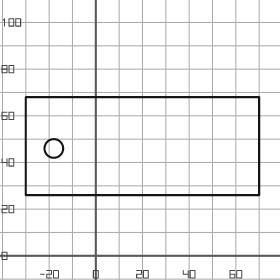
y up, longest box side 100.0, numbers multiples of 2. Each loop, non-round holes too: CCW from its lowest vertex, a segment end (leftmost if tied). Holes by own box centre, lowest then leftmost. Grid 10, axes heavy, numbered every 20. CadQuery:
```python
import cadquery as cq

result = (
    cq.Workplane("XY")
    .moveTo(-30.0, 26.0)
    .lineTo(70.0, 26.0)
    .lineTo(70.0, 68.0)
    .lineTo(-30.0, 68.0)
    .close()
    .moveTo(-18.0, 46.0)
    .circle(4.0)
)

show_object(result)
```